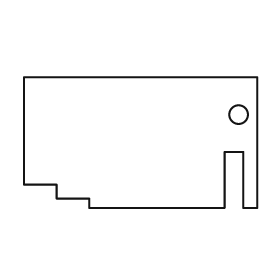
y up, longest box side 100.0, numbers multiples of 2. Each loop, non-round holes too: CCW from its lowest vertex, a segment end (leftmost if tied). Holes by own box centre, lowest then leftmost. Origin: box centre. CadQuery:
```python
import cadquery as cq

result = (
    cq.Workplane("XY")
    .moveTo(-22.0, -28.0)
    .lineTo(36.0, -28.0)
    .lineTo(36.0, -4.0)
    .lineTo(44.0, -4.0)
    .lineTo(44.0, -28.0)
    .lineTo(50.0, -28.0)
    .lineTo(50.0, 28.0)
    .lineTo(-50.0, 28.0)
    .lineTo(-50.0, -18.0)
    .lineTo(-36.0, -18.0)
    .lineTo(-36.0, -24.0)
    .lineTo(-22.0, -24.0)
    .close()
    .moveTo(42.0, 12.0)
    .circle(4.0)
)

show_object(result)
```